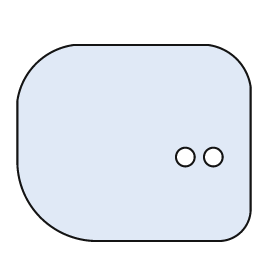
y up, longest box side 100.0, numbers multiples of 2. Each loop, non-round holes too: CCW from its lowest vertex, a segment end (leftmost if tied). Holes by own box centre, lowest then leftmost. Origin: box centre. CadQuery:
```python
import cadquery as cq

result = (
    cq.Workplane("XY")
    .moveTo(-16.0, -42.0)
    .lineTo(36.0, -42.0)
    .threePointArc((46.0, -38.0), (50.0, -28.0))
    .lineTo(50.0, 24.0)
    .threePointArc((44.0, 36.0), (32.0, 42.0))
    .lineTo(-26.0, 42.0)
    .threePointArc((-42.0, 34.0), (-50.0, 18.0))
    .lineTo(-50.0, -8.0)
    .threePointArc((-40.0, -32.0), (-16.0, -42.0))
    .close()
    .moveTo(22.0, -6.0)
    .circle(4.0)
    .moveTo(34.0, -6.0)
    .circle(4.0)
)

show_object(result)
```